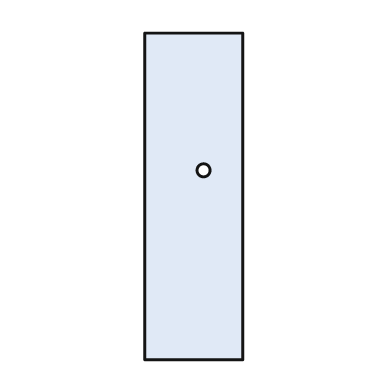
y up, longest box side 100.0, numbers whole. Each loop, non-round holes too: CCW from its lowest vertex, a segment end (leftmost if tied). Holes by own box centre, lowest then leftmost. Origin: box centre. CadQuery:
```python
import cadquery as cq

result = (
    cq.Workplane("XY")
    .moveTo(-15.0, -50.0)
    .lineTo(15.0, -50.0)
    .lineTo(15.0, 50.0)
    .lineTo(-15.0, 50.0)
    .close()
    .moveTo(3.0, 8.0)
    .circle(2.0)
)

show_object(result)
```